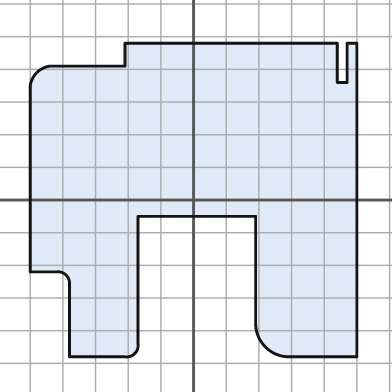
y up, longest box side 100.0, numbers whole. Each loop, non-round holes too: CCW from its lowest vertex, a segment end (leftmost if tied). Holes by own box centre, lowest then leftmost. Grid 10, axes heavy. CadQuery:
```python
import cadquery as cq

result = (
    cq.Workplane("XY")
    .moveTo(-38.0, -48.0)
    .lineTo(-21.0, -48.0)
    .threePointArc((-18.0, -47.0), (-17.0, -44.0))
    .lineTo(-17.0, -5.0)
    .lineTo(19.0, -5.0)
    .lineTo(19.0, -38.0)
    .threePointArc((22.0, -45.0), (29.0, -48.0))
    .lineTo(50.0, -48.0)
    .lineTo(50.0, 48.0)
    .lineTo(47.0, 48.0)
    .lineTo(47.0, 36.0)
    .lineTo(44.0, 36.0)
    .lineTo(44.0, 48.0)
    .lineTo(-21.0, 48.0)
    .lineTo(-21.0, 41.0)
    .lineTo(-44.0, 41.0)
    .threePointArc((-48.0, 39.0), (-50.0, 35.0))
    .lineTo(-50.0, -22.0)
    .lineTo(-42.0, -22.0)
    .threePointArc((-39.0, -23.0), (-38.0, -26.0))
    .close()
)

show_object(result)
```